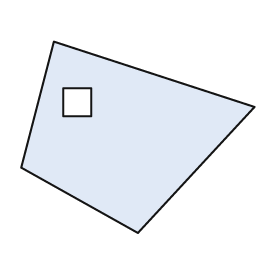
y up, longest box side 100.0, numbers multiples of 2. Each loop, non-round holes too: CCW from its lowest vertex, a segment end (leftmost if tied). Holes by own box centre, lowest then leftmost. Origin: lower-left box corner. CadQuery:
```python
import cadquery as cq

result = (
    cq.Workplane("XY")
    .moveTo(50.0, 0.0)
    .lineTo(100.0, 54.0)
    .lineTo(14.0, 82.0)
    .lineTo(0.0, 28.0)
    .close()
    .moveTo(18.0, 50.0)
    .lineTo(30.0, 50.0)
    .lineTo(30.0, 62.0)
    .lineTo(18.0, 62.0)
    .close()
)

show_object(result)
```